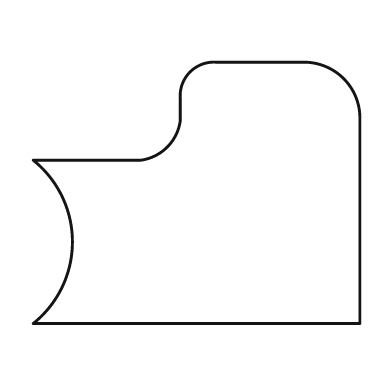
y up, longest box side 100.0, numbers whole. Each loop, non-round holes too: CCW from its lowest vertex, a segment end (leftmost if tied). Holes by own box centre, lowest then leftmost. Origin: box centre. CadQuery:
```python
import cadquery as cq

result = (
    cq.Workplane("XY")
    .moveTo(-50.0, -40.0)
    .lineTo(50.0, -40.0)
    .lineTo(50.0, 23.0)
    .threePointArc((45.0, 35.0), (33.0, 40.0))
    .lineTo(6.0, 40.0)
    .threePointArc((-2.0, 37.0), (-5.0, 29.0))
    .lineTo(-5.0, 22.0)
    .threePointArc((-9.0, 14.0), (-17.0, 10.0))
    .lineTo(-50.0, 10.0)
    .threePointArc((-38.0, -15.0), (-50.0, -40.0))
    .close()
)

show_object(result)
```